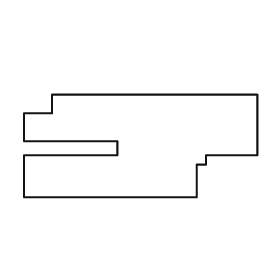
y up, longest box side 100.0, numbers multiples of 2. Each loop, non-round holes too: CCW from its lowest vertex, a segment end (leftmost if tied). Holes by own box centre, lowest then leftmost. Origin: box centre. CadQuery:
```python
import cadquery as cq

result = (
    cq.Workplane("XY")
    .moveTo(-50.0, -22.0)
    .lineTo(24.0, -22.0)
    .lineTo(24.0, -8.0)
    .lineTo(28.0, -8.0)
    .lineTo(28.0, -4.0)
    .lineTo(50.0, -4.0)
    .lineTo(50.0, 22.0)
    .lineTo(-38.0, 22.0)
    .lineTo(-38.0, 14.0)
    .lineTo(-50.0, 14.0)
    .lineTo(-50.0, 2.0)
    .lineTo(-10.0, 2.0)
    .lineTo(-10.0, -4.0)
    .lineTo(-50.0, -4.0)
    .close()
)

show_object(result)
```